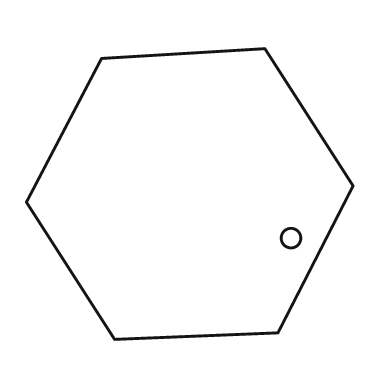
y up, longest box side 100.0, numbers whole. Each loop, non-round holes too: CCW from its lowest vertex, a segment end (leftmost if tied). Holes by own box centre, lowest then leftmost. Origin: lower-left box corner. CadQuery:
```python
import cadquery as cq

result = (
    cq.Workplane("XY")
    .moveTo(27.0, 0.0)
    .lineTo(77.0, 2.0)
    .lineTo(100.0, 47.0)
    .lineTo(73.0, 89.0)
    .lineTo(23.0, 86.0)
    .lineTo(0.0, 42.0)
    .close()
    .moveTo(81.0, 31.0)
    .circle(3.0)
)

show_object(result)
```